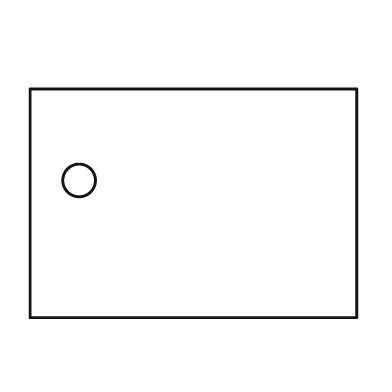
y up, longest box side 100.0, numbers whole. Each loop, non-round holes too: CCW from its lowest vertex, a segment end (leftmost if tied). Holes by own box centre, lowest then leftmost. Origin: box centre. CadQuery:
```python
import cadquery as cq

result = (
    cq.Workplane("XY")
    .moveTo(-50.0, -35.0)
    .lineTo(50.0, -35.0)
    .lineTo(50.0, 35.0)
    .lineTo(-50.0, 35.0)
    .close()
    .moveTo(-35.0, 7.0)
    .circle(5.0)
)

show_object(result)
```